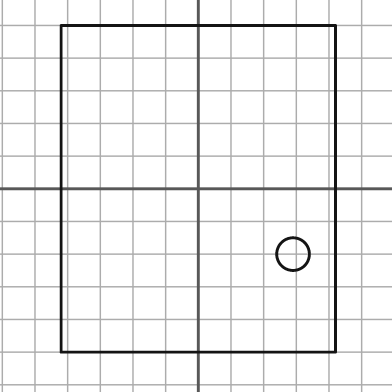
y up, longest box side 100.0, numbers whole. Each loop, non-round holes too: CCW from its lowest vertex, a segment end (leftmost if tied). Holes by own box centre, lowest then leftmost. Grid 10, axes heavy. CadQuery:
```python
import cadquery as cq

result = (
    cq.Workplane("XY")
    .moveTo(-42.0, -50.0)
    .lineTo(42.0, -50.0)
    .lineTo(42.0, 50.0)
    .lineTo(-42.0, 50.0)
    .close()
    .moveTo(29.0, -20.0)
    .circle(5.0)
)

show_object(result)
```